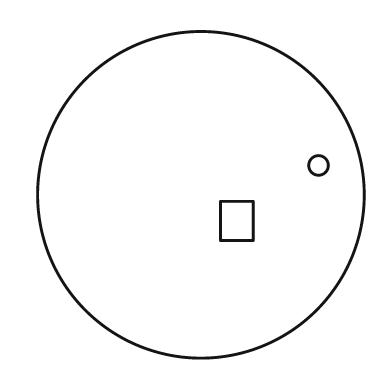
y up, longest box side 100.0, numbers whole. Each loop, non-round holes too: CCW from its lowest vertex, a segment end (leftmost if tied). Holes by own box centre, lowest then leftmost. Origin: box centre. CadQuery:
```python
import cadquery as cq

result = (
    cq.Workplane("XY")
    .moveTo(0.0, 0.0)
    .circle(50.0)
    .moveTo(6.0, -14.0)
    .lineTo(16.0, -14.0)
    .lineTo(16.0, -2.0)
    .lineTo(6.0, -2.0)
    .close()
    .moveTo(36.0, 9.0)
    .circle(3.0)
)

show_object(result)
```